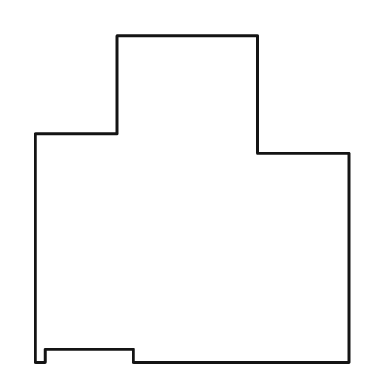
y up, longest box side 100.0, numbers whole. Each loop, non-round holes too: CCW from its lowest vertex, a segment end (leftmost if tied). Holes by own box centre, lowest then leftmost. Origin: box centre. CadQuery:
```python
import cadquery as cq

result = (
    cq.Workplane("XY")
    .moveTo(-48.0, -50.0)
    .lineTo(-45.0, -50.0)
    .lineTo(-45.0, -46.0)
    .lineTo(-18.0, -46.0)
    .lineTo(-18.0, -50.0)
    .lineTo(48.0, -50.0)
    .lineTo(48.0, 14.0)
    .lineTo(20.0, 14.0)
    .lineTo(20.0, 50.0)
    .lineTo(-23.0, 50.0)
    .lineTo(-23.0, 20.0)
    .lineTo(-48.0, 20.0)
    .close()
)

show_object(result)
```